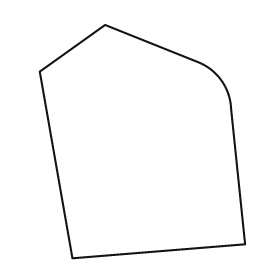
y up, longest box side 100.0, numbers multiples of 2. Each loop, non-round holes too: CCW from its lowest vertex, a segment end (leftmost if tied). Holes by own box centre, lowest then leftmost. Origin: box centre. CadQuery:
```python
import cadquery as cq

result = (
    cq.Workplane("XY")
    .moveTo(-30.0, -50.0)
    .lineTo(44.0, -44.0)
    .lineTo(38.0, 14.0)
    .threePointArc((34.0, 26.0), (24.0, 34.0))
    .lineTo(-16.0, 50.0)
    .lineTo(-44.0, 30.0)
    .close()
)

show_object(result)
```